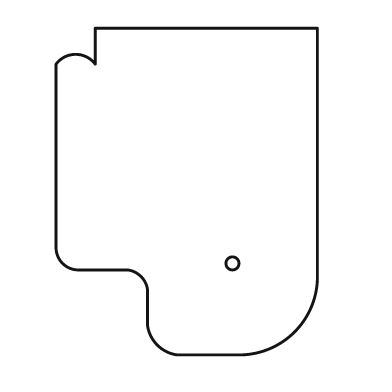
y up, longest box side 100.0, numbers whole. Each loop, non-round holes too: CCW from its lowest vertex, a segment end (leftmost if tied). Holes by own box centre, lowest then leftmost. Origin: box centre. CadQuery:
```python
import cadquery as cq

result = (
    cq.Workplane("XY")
    .moveTo(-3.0, -50.0)
    .lineTo(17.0, -50.0)
    .threePointArc((33.0, -43.0), (40.0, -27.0))
    .lineTo(40.0, 50.0)
    .lineTo(-28.0, 50.0)
    .lineTo(-28.0, 39.0)
    .threePointArc((-34.0, 42.0), (-40.0, 39.0))
    .lineTo(-40.0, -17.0)
    .threePointArc((-38.0, -22.0), (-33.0, -24.0))
    .lineTo(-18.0, -24.0)
    .threePointArc((-14.0, -26.0), (-12.0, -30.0))
    .lineTo(-12.0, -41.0)
    .threePointArc((-9.0, -47.0), (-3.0, -50.0))
    .close()
    .moveTo(14.0, -22.0)
    .circle(2.0)
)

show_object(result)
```